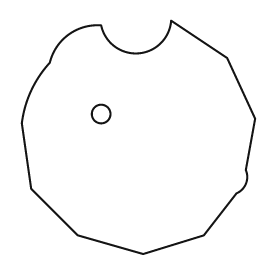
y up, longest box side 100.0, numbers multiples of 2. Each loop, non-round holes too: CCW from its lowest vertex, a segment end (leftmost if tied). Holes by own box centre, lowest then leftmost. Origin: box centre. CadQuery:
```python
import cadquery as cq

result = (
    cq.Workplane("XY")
    .moveTo(2.0, -50.0)
    .lineTo(28.0, -42.0)
    .lineTo(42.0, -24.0)
    .threePointArc((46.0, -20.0), (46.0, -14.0))
    .lineTo(50.0, 8.0)
    .lineTo(38.0, 34.0)
    .lineTo(14.0, 50.0)
    .threePointArc((0.0, 36.0), (-16.0, 48.0))
    .threePointArc((-30.0, 44.0), (-38.0, 32.0))
    .threePointArc((-46.0, 20.0), (-50.0, 6.0))
    .lineTo(-46.0, -22.0)
    .lineTo(-26.0, -42.0)
    .close()
    .moveTo(-16.0, 10.0)
    .circle(4.0)
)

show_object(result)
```